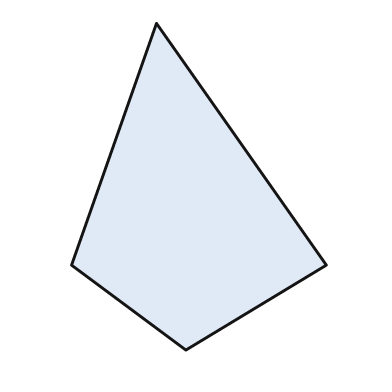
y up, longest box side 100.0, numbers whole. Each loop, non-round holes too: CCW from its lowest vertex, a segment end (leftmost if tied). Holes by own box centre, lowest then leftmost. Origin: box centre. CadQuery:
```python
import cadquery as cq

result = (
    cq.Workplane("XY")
    .moveTo(-4.0, -50.0)
    .lineTo(39.0, -24.0)
    .lineTo(-13.0, 50.0)
    .lineTo(-39.0, -24.0)
    .close()
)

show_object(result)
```